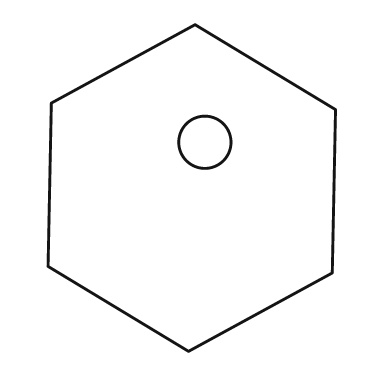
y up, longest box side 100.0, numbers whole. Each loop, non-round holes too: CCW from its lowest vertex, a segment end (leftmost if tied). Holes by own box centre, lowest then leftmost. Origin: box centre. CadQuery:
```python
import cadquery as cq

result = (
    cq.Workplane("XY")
    .moveTo(-1.0, -50.0)
    .lineTo(43.0, -26.0)
    .lineTo(44.0, 24.0)
    .lineTo(1.0, 50.0)
    .lineTo(-43.0, 26.0)
    .lineTo(-44.0, -24.0)
    .close()
    .moveTo(4.0, 14.0)
    .circle(8.0)
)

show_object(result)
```